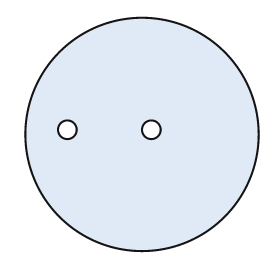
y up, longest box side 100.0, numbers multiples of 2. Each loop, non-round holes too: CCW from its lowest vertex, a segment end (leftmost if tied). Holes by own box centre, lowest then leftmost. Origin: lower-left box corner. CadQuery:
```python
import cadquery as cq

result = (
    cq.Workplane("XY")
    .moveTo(50.0, 50.0)
    .circle(50.0)
    .moveTo(18.0, 52.0)
    .circle(4.0)
    .moveTo(54.0, 52.0)
    .circle(4.0)
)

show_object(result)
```